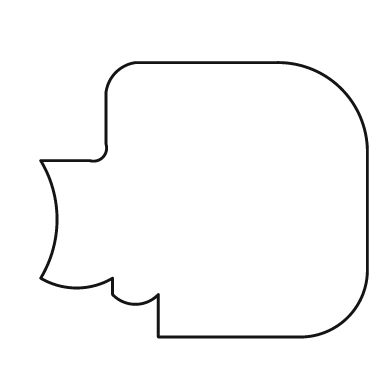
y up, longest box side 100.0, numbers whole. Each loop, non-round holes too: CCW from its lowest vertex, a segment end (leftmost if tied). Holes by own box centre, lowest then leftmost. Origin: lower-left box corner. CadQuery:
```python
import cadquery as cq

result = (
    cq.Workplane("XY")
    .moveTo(36.0, 0.0)
    .lineTo(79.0, 0.0)
    .threePointArc((94.0, 6.0), (100.0, 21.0))
    .lineTo(100.0, 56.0)
    .threePointArc((92.0, 76.0), (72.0, 84.0))
    .lineTo(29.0, 84.0)
    .threePointArc((23.0, 81.0), (20.0, 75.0))
    .lineTo(20.0, 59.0)
    .threePointArc((19.0, 55.0), (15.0, 54.0))
    .lineTo(0.0, 54.0)
    .threePointArc((5.0, 36.0), (0.0, 18.0))
    .threePointArc((11.0, 15.0), (22.0, 18.0))
    .lineTo(22.0, 13.0)
    .threePointArc((29.0, 10.0), (36.0, 13.0))
    .close()
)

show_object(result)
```